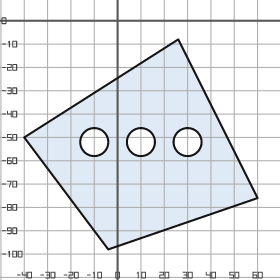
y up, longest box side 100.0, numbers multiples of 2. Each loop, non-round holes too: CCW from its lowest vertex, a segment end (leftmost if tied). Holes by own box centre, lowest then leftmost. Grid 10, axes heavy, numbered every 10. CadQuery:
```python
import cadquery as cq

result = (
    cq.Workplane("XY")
    .moveTo(-4.0, -98.0)
    .lineTo(60.0, -76.0)
    .lineTo(26.0, -8.0)
    .lineTo(-40.0, -50.0)
    .close()
    .moveTo(-10.0, -52.0)
    .circle(6.0)
    .moveTo(10.0, -52.0)
    .circle(6.0)
    .moveTo(30.0, -52.0)
    .circle(6.0)
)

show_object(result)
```